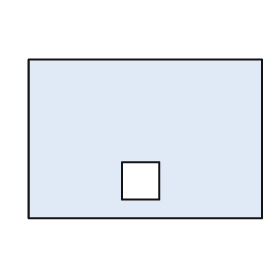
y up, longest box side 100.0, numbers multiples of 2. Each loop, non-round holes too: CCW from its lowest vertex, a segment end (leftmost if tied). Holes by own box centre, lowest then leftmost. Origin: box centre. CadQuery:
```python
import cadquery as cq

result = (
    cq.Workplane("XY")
    .moveTo(-50.0, -34.0)
    .lineTo(50.0, -34.0)
    .lineTo(50.0, 34.0)
    .lineTo(-50.0, 34.0)
    .close()
    .moveTo(-10.0, -26.0)
    .lineTo(6.0, -26.0)
    .lineTo(6.0, -10.0)
    .lineTo(-10.0, -10.0)
    .close()
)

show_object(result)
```